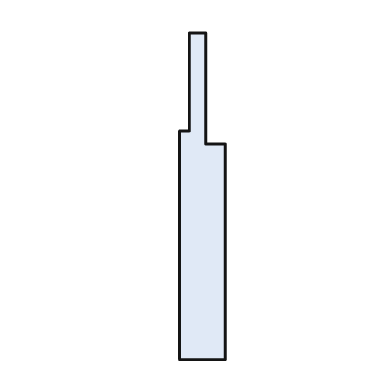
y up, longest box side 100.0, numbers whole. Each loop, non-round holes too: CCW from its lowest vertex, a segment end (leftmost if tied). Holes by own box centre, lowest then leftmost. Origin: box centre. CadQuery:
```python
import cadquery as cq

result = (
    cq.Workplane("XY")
    .moveTo(-7.0, -50.0)
    .lineTo(7.0, -50.0)
    .lineTo(7.0, 16.0)
    .lineTo(1.0, 16.0)
    .lineTo(1.0, 50.0)
    .lineTo(-4.0, 50.0)
    .lineTo(-4.0, 20.0)
    .lineTo(-7.0, 20.0)
    .close()
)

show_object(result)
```